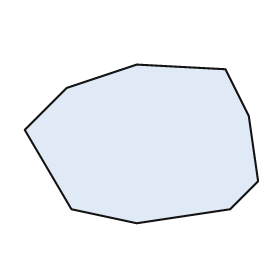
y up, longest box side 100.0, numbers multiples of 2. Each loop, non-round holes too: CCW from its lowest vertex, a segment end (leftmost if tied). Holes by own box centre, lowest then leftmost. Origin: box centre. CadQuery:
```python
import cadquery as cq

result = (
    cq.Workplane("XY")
    .moveTo(-2.0, -34.0)
    .lineTo(38.0, -28.0)
    .lineTo(50.0, -16.0)
    .lineTo(46.0, 12.0)
    .lineTo(36.0, 32.0)
    .lineTo(-2.0, 34.0)
    .lineTo(-32.0, 24.0)
    .lineTo(-50.0, 6.0)
    .lineTo(-30.0, -28.0)
    .close()
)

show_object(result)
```